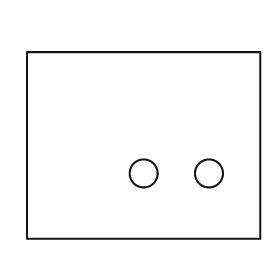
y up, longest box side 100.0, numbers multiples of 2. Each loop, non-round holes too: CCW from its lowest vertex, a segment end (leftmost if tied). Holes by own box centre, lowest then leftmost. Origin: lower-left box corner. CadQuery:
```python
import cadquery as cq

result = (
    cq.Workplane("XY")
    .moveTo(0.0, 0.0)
    .lineTo(100.0, 0.0)
    .lineTo(100.0, 80.0)
    .lineTo(0.0, 80.0)
    .close()
    .moveTo(50.0, 28.0)
    .circle(6.0)
    .moveTo(78.0, 28.0)
    .circle(6.0)
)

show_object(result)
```